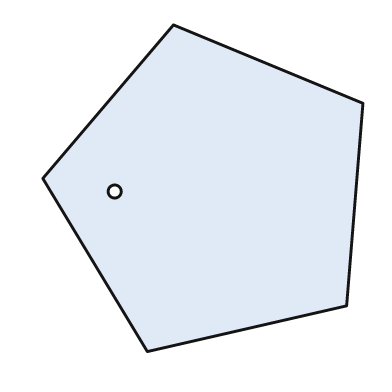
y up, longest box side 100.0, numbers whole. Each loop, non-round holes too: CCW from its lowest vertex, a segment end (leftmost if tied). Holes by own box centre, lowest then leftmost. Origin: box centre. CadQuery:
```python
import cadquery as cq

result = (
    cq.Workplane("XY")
    .moveTo(-17.0, -50.0)
    .lineTo(44.0, -36.0)
    .lineTo(49.0, 26.0)
    .lineTo(-9.0, 50.0)
    .lineTo(-49.0, 3.0)
    .close()
    .moveTo(-27.0, -1.0)
    .circle(2.0)
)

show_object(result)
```